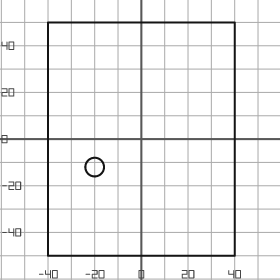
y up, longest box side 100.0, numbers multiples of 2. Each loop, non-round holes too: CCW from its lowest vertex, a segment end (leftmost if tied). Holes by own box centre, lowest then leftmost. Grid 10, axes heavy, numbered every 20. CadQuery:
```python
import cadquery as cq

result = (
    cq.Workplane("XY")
    .moveTo(-40.0, -50.0)
    .lineTo(40.0, -50.0)
    .lineTo(40.0, 50.0)
    .lineTo(-40.0, 50.0)
    .close()
    .moveTo(-20.0, -12.0)
    .circle(4.0)
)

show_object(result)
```